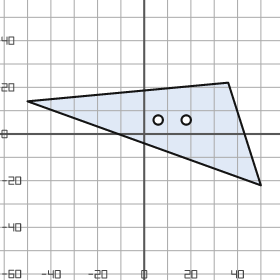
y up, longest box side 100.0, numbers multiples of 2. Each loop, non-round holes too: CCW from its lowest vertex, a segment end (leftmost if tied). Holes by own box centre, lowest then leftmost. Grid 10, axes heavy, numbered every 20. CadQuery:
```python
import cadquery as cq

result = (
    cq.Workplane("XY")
    .moveTo(50.0, -22.0)
    .lineTo(36.0, 22.0)
    .lineTo(-50.0, 14.0)
    .close()
    .moveTo(6.0, 6.0)
    .circle(2.0)
    .moveTo(18.0, 6.0)
    .circle(2.0)
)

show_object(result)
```